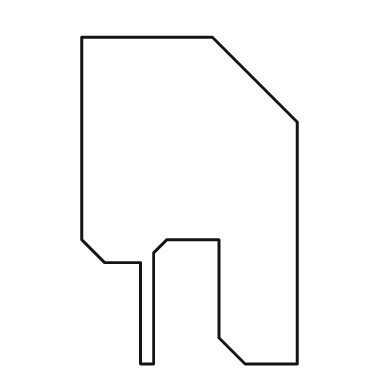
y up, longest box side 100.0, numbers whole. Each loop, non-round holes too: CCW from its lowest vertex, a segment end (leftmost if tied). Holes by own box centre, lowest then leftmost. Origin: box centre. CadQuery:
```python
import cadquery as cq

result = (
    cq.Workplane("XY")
    .moveTo(-15.0, -50.0)
    .lineTo(-11.0, -50.0)
    .lineTo(-11.0, -16.0)
    .lineTo(-7.0, -12.0)
    .lineTo(9.0, -12.0)
    .lineTo(9.0, -42.0)
    .lineTo(17.0, -50.0)
    .lineTo(33.0, -50.0)
    .lineTo(33.0, 24.0)
    .lineTo(7.0, 50.0)
    .lineTo(-33.0, 50.0)
    .lineTo(-33.0, -12.0)
    .lineTo(-26.0, -19.0)
    .lineTo(-15.0, -19.0)
    .close()
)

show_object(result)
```